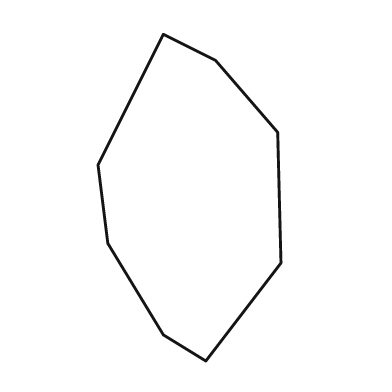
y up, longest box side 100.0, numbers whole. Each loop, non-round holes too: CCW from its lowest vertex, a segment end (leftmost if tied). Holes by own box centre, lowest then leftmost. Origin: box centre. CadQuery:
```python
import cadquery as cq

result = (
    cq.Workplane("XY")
    .moveTo(5.0, -50.0)
    .lineTo(28.0, -20.0)
    .lineTo(27.0, 20.0)
    .lineTo(8.0, 42.0)
    .lineTo(-8.0, 50.0)
    .lineTo(-28.0, 10.0)
    .lineTo(-25.0, -14.0)
    .lineTo(-8.0, -42.0)
    .close()
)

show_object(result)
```